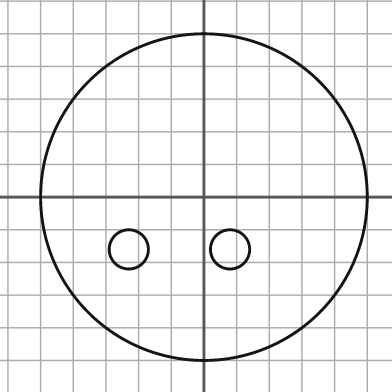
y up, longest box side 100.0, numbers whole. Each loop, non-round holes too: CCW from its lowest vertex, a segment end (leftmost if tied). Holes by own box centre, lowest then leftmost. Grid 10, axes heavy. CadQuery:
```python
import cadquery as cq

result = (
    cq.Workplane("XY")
    .moveTo(0.0, 0.0)
    .circle(50.0)
    .moveTo(-23.0, -16.0)
    .circle(6.0)
    .moveTo(8.0, -16.0)
    .circle(6.0)
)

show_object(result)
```